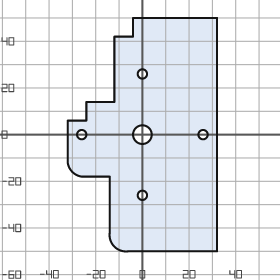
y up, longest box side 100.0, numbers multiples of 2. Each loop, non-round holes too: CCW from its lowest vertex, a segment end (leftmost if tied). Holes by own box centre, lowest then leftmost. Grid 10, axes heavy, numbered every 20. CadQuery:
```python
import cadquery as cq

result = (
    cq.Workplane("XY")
    .moveTo(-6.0, -50.0)
    .lineTo(32.0, -50.0)
    .lineTo(32.0, 50.0)
    .lineTo(-4.0, 50.0)
    .lineTo(-4.0, 42.0)
    .lineTo(-12.0, 42.0)
    .lineTo(-12.0, 14.0)
    .lineTo(-24.0, 14.0)
    .lineTo(-24.0, 6.0)
    .lineTo(-32.0, 6.0)
    .lineTo(-32.0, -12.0)
    .threePointArc((-30.0, -16.0), (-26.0, -18.0))
    .lineTo(-14.0, -18.0)
    .lineTo(-14.0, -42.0)
    .threePointArc((-12.0, -48.0), (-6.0, -50.0))
    .close()
    .moveTo(0.0, -26.0)
    .circle(2.0)
    .moveTo(-26.0, 0.0)
    .circle(2.0)
    .moveTo(0.0, 0.0)
    .circle(4.0)
    .moveTo(26.0, 0.0)
    .circle(2.0)
    .moveTo(0.0, 26.0)
    .circle(2.0)
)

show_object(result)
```